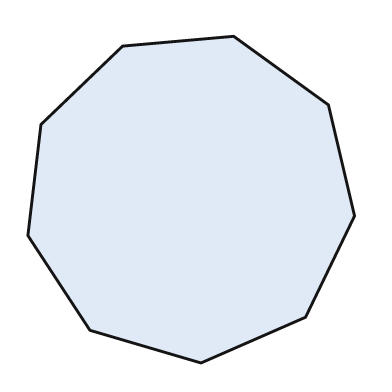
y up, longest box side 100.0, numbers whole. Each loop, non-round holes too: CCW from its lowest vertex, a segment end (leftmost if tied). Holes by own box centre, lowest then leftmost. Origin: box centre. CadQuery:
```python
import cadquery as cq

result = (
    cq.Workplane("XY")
    .moveTo(3.0, -50.0)
    .lineTo(35.0, -36.0)
    .lineTo(50.0, -5.0)
    .lineTo(42.0, 29.0)
    .lineTo(13.0, 50.0)
    .lineTo(-21.0, 47.0)
    .lineTo(-46.0, 23.0)
    .lineTo(-50.0, -11.0)
    .lineTo(-31.0, -40.0)
    .close()
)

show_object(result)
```